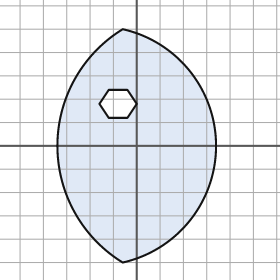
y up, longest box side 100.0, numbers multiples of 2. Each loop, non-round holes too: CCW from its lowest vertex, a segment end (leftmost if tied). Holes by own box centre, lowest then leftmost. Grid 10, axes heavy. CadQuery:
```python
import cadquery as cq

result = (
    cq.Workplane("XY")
    .moveTo(-6.0, -50.0)
    .threePointArc((34.0, 0.0), (-6.0, 50.0))
    .threePointArc((-34.0, 0.0), (-6.0, -50.0))
    .close()
    .moveTo(-12.0, 12.0)
    .lineTo(-4.0, 12.0)
    .lineTo(0.0, 18.0)
    .lineTo(-4.0, 24.0)
    .lineTo(-12.0, 24.0)
    .lineTo(-16.0, 18.0)
    .close()
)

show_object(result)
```